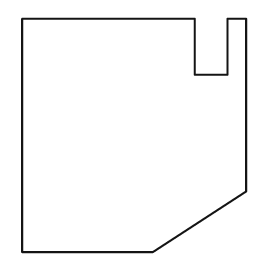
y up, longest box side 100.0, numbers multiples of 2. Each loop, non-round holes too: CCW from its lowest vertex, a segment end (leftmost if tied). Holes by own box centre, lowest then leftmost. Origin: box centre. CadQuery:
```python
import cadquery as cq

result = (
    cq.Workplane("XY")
    .moveTo(-48.0, -50.0)
    .lineTo(8.0, -50.0)
    .lineTo(48.0, -24.0)
    .lineTo(48.0, 50.0)
    .lineTo(40.0, 50.0)
    .lineTo(40.0, 26.0)
    .lineTo(26.0, 26.0)
    .lineTo(26.0, 50.0)
    .lineTo(-48.0, 50.0)
    .close()
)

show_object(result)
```